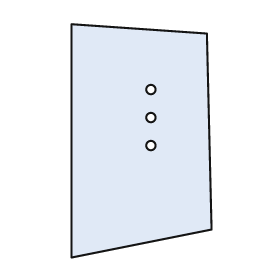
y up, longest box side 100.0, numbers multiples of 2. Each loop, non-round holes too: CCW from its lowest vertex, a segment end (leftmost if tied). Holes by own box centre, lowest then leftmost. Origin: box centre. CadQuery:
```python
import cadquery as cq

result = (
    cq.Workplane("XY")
    .moveTo(-30.0, -50.0)
    .lineTo(30.0, -38.0)
    .lineTo(28.0, 46.0)
    .lineTo(-30.0, 50.0)
    .close()
    .moveTo(4.0, -2.0)
    .circle(2.0)
    .moveTo(4.0, 10.0)
    .circle(2.0)
    .moveTo(4.0, 22.0)
    .circle(2.0)
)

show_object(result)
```